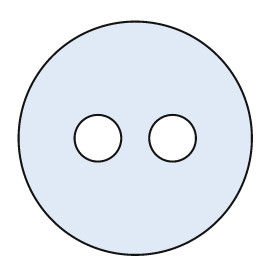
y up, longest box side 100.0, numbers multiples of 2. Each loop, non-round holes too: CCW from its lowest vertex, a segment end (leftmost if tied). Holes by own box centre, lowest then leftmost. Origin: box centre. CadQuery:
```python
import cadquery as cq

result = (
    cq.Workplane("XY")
    .moveTo(0.0, 0.0)
    .circle(50.0)
    .moveTo(-16.0, 0.0)
    .circle(10.0)
    .moveTo(16.0, 0.0)
    .circle(10.0)
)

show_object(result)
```